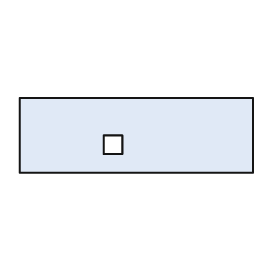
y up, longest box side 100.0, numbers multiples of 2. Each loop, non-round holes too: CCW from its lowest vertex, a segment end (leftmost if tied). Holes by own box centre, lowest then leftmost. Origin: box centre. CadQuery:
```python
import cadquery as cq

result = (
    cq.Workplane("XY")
    .moveTo(-50.0, -16.0)
    .lineTo(50.0, -16.0)
    .lineTo(50.0, 16.0)
    .lineTo(-50.0, 16.0)
    .close()
    .moveTo(-14.0, -8.0)
    .lineTo(-6.0, -8.0)
    .lineTo(-6.0, 0.0)
    .lineTo(-14.0, 0.0)
    .close()
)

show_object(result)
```